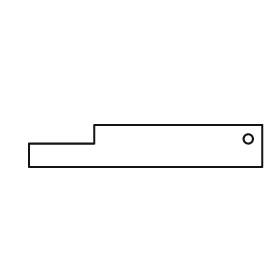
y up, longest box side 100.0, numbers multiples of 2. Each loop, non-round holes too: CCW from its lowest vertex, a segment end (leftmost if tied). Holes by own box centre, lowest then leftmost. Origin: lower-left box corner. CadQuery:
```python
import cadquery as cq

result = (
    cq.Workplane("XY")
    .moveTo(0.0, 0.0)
    .lineTo(100.0, 0.0)
    .lineTo(100.0, 18.0)
    .lineTo(28.0, 18.0)
    .lineTo(28.0, 10.0)
    .lineTo(0.0, 10.0)
    .close()
    .moveTo(94.0, 12.0)
    .circle(2.0)
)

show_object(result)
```